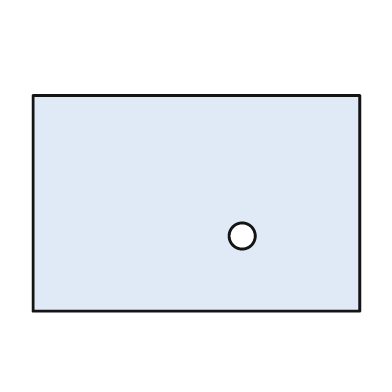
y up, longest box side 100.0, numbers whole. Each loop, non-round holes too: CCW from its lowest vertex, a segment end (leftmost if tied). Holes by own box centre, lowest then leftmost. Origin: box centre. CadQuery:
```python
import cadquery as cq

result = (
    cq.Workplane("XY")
    .moveTo(-50.0, -33.0)
    .lineTo(50.0, -33.0)
    .lineTo(50.0, 33.0)
    .lineTo(-50.0, 33.0)
    .close()
    .moveTo(14.0, -10.0)
    .circle(4.0)
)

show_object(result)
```